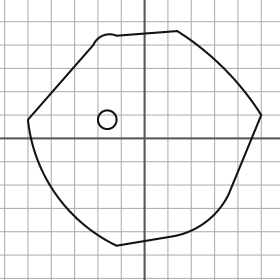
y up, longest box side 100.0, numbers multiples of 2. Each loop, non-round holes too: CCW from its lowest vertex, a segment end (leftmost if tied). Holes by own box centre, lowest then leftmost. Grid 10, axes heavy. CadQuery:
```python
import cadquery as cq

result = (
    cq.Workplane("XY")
    .moveTo(-12.0, -46.0)
    .lineTo(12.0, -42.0)
    .threePointArc((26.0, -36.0), (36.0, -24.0))
    .lineTo(50.0, 10.0)
    .threePointArc((34.0, 30.0), (14.0, 46.0))
    .lineTo(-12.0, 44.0)
    .threePointArc((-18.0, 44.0), (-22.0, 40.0))
    .lineTo(-50.0, 8.0)
    .threePointArc((-38.0, -24.0), (-12.0, -46.0))
    .close()
    .moveTo(-16.0, 8.0)
    .circle(4.0)
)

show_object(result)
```